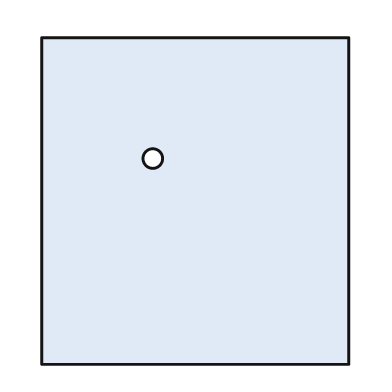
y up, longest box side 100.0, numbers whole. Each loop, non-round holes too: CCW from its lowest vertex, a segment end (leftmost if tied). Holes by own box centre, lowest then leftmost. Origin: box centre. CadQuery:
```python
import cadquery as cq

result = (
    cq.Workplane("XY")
    .moveTo(-47.0, -50.0)
    .lineTo(47.0, -50.0)
    .lineTo(47.0, 50.0)
    .lineTo(-47.0, 50.0)
    .close()
    .moveTo(-13.0, 13.0)
    .circle(3.0)
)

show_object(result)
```